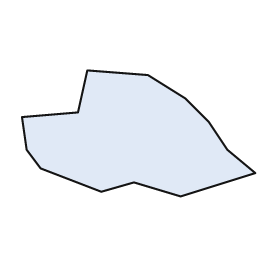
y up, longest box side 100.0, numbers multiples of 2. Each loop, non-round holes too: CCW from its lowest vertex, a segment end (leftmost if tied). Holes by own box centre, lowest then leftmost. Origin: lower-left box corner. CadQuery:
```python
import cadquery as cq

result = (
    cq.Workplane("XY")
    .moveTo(68.0, 0.0)
    .lineTo(100.0, 10.0)
    .lineTo(88.0, 20.0)
    .lineTo(80.0, 32.0)
    .lineTo(70.0, 42.0)
    .lineTo(54.0, 52.0)
    .lineTo(28.0, 54.0)
    .lineTo(24.0, 36.0)
    .lineTo(0.0, 34.0)
    .lineTo(2.0, 20.0)
    .lineTo(8.0, 12.0)
    .lineTo(34.0, 2.0)
    .lineTo(48.0, 6.0)
    .close()
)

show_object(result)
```